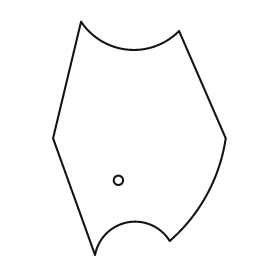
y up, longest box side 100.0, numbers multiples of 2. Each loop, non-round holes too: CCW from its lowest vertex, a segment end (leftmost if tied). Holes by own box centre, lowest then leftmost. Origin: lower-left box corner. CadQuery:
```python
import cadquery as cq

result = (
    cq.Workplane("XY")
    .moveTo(18.0, 0.0)
    .threePointArc((32.0, 14.0), (50.0, 6.0))
    .threePointArc((66.0, 26.0), (74.0, 50.0))
    .lineTo(54.0, 96.0)
    .threePointArc((32.0, 88.0), (12.0, 100.0))
    .lineTo(0.0, 50.0)
    .close()
    .moveTo(28.0, 32.0)
    .circle(2.0)
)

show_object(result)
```